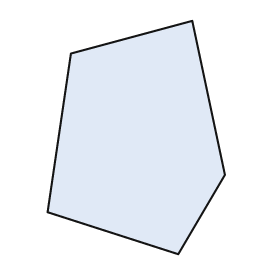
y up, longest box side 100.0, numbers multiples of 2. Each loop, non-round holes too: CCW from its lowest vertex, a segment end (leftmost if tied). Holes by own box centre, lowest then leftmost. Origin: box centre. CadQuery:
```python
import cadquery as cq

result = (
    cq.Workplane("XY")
    .moveTo(18.0, -50.0)
    .lineTo(38.0, -16.0)
    .lineTo(24.0, 50.0)
    .lineTo(-28.0, 36.0)
    .lineTo(-38.0, -32.0)
    .close()
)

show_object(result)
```